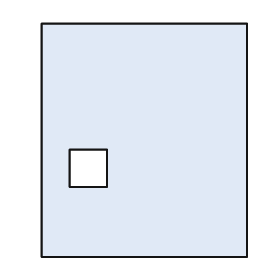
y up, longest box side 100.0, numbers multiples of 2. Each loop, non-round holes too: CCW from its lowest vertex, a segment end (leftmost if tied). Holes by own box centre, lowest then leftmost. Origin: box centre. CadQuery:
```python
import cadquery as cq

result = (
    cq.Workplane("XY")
    .moveTo(-44.0, -50.0)
    .lineTo(44.0, -50.0)
    .lineTo(44.0, 50.0)
    .lineTo(-44.0, 50.0)
    .close()
    .moveTo(-32.0, -20.0)
    .lineTo(-16.0, -20.0)
    .lineTo(-16.0, -4.0)
    .lineTo(-32.0, -4.0)
    .close()
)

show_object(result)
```